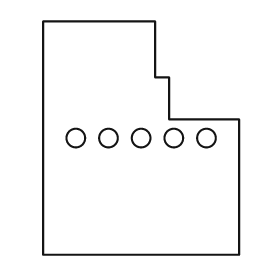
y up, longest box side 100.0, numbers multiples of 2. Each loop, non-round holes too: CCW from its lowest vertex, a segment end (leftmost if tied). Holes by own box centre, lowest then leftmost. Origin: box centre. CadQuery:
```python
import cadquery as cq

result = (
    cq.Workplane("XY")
    .moveTo(-42.0, -50.0)
    .lineTo(42.0, -50.0)
    .lineTo(42.0, 8.0)
    .lineTo(12.0, 8.0)
    .lineTo(12.0, 26.0)
    .lineTo(6.0, 26.0)
    .lineTo(6.0, 50.0)
    .lineTo(-42.0, 50.0)
    .close()
    .moveTo(-28.0, 0.0)
    .circle(4.0)
    .moveTo(-14.0, 0.0)
    .circle(4.0)
    .moveTo(0.0, 0.0)
    .circle(4.0)
    .moveTo(14.0, 0.0)
    .circle(4.0)
    .moveTo(28.0, 0.0)
    .circle(4.0)
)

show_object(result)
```